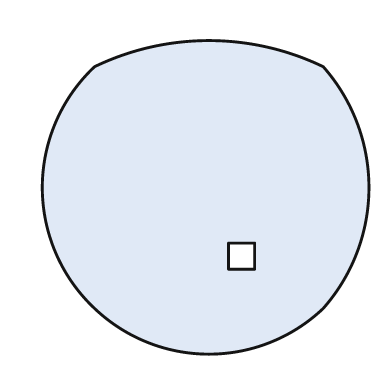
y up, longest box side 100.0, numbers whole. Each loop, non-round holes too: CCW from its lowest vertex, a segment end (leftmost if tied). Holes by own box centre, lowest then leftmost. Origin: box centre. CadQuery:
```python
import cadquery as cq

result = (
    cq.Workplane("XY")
    .moveTo(-34.0, -34.0)
    .threePointArc((1.0, -48.0), (36.0, -34.0))
    .threePointArc((50.0, 3.0), (36.0, 40.0))
    .threePointArc((1.0, 48.0), (-34.0, 40.0))
    .threePointArc((-50.0, 3.0), (-34.0, -34.0))
    .close()
    .moveTo(7.0, -22.0)
    .lineTo(15.0, -22.0)
    .lineTo(15.0, -14.0)
    .lineTo(7.0, -14.0)
    .close()
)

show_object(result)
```